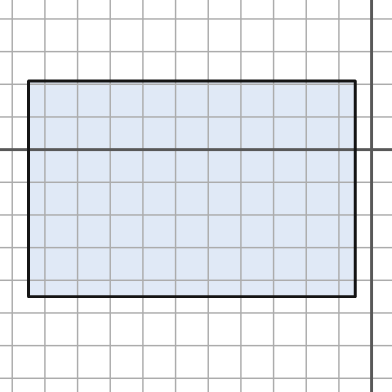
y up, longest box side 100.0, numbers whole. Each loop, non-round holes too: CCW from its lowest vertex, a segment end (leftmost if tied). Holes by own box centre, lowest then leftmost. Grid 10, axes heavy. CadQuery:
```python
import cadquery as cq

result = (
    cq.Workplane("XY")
    .moveTo(-105.0, -45.0)
    .lineTo(-5.0, -45.0)
    .lineTo(-5.0, 21.0)
    .lineTo(-105.0, 21.0)
    .close()
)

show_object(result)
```